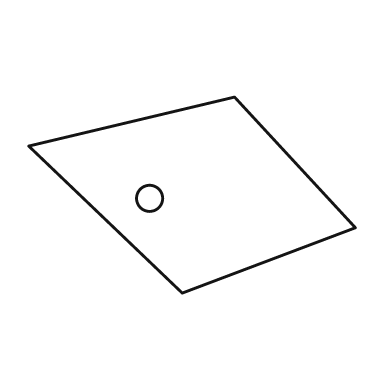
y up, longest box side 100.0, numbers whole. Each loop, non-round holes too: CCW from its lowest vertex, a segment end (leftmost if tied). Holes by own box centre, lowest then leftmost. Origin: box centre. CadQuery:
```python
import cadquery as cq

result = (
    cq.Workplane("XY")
    .moveTo(-3.0, -30.0)
    .lineTo(50.0, -10.0)
    .lineTo(13.0, 30.0)
    .lineTo(-50.0, 15.0)
    .close()
    .moveTo(-13.0, -1.0)
    .circle(4.0)
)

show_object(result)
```